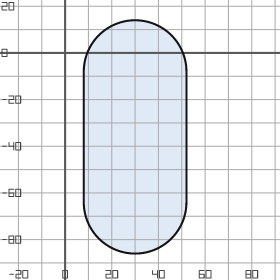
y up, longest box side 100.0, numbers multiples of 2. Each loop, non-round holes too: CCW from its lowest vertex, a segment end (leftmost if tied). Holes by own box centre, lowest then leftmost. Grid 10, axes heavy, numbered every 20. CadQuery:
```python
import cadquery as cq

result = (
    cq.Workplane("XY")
    .moveTo(8.0, -64.0)
    .threePointArc((30.0, -86.0), (52.0, -64.0))
    .lineTo(52.0, -8.0)
    .threePointArc((30.0, 14.0), (8.0, -8.0))
    .close()
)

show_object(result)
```